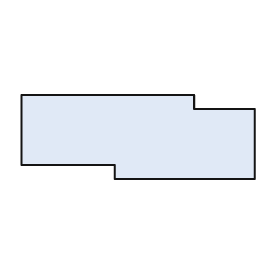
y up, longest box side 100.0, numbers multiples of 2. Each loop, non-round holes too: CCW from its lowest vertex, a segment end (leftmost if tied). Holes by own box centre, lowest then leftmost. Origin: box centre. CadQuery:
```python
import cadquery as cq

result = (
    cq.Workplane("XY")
    .moveTo(-10.0, -18.0)
    .lineTo(50.0, -18.0)
    .lineTo(50.0, 12.0)
    .lineTo(24.0, 12.0)
    .lineTo(24.0, 18.0)
    .lineTo(-50.0, 18.0)
    .lineTo(-50.0, -12.0)
    .lineTo(-10.0, -12.0)
    .close()
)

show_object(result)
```